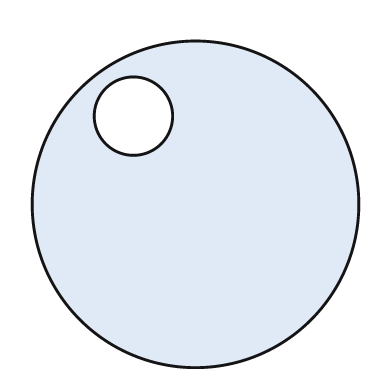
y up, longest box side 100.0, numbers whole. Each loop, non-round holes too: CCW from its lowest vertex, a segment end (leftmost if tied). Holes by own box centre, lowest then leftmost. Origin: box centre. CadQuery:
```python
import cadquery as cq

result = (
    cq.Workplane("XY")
    .moveTo(0.0, 0.0)
    .circle(50.0)
    .moveTo(-19.0, 27.0)
    .circle(12.0)
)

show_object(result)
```